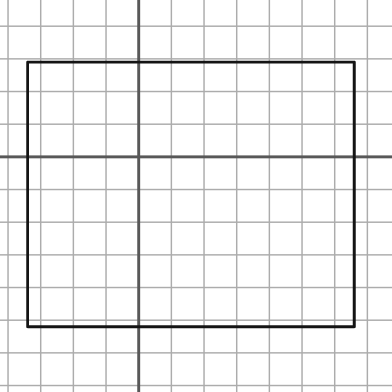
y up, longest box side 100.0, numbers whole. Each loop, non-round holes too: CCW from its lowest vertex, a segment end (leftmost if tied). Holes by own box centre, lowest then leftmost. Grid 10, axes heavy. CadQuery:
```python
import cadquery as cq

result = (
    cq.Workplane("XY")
    .moveTo(-34.0, -52.0)
    .lineTo(66.0, -52.0)
    .lineTo(66.0, 29.0)
    .lineTo(-34.0, 29.0)
    .close()
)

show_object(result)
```